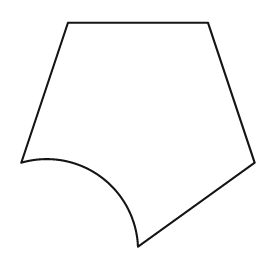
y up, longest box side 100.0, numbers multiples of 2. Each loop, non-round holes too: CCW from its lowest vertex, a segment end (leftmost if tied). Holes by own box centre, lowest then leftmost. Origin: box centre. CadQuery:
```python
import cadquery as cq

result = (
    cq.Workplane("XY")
    .moveTo(0.0, -48.0)
    .lineTo(50.0, -12.0)
    .lineTo(30.0, 48.0)
    .lineTo(-30.0, 48.0)
    .lineTo(-50.0, -12.0)
    .threePointArc((-16.0, -18.0), (0.0, -48.0))
    .close()
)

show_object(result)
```